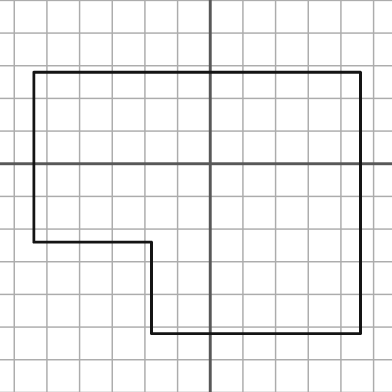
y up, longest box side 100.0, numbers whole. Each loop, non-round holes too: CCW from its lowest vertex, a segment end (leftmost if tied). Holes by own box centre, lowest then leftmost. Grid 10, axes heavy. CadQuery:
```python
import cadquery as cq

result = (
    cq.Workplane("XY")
    .moveTo(-18.0, -52.0)
    .lineTo(46.0, -52.0)
    .lineTo(46.0, 28.0)
    .lineTo(-54.0, 28.0)
    .lineTo(-54.0, -24.0)
    .lineTo(-18.0, -24.0)
    .close()
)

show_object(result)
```